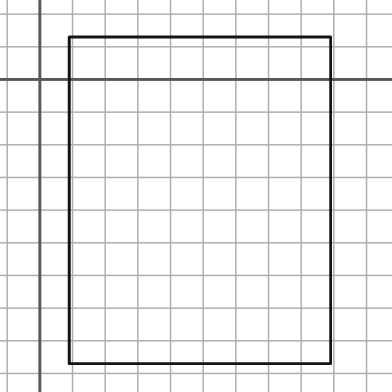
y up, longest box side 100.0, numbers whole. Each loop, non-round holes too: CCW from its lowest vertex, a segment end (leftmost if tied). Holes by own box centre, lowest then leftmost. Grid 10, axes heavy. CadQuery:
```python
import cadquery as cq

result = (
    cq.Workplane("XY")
    .moveTo(9.0, -87.0)
    .lineTo(89.0, -87.0)
    .lineTo(89.0, 13.0)
    .lineTo(9.0, 13.0)
    .close()
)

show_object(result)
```